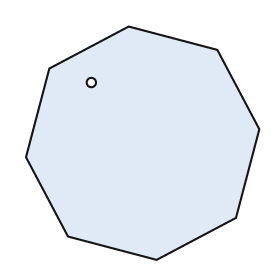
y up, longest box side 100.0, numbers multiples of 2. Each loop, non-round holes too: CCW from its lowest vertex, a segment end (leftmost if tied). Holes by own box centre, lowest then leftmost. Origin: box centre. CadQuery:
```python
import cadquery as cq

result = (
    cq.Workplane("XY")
    .moveTo(6.0, -50.0)
    .lineTo(40.0, -32.0)
    .lineTo(50.0, 6.0)
    .lineTo(32.0, 40.0)
    .lineTo(-6.0, 50.0)
    .lineTo(-40.0, 32.0)
    .lineTo(-50.0, -6.0)
    .lineTo(-32.0, -40.0)
    .close()
    .moveTo(-22.0, 26.0)
    .circle(2.0)
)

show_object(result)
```